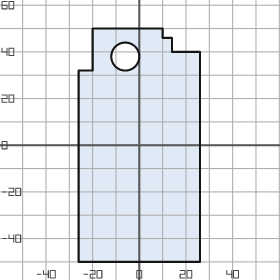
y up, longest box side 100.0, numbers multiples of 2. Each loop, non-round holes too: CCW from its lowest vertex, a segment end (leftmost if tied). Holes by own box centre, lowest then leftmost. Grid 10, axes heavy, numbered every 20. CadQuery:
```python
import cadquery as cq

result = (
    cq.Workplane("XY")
    .moveTo(-26.0, -50.0)
    .lineTo(26.0, -50.0)
    .lineTo(26.0, 40.0)
    .lineTo(14.0, 40.0)
    .lineTo(14.0, 46.0)
    .lineTo(10.0, 46.0)
    .lineTo(10.0, 50.0)
    .lineTo(-20.0, 50.0)
    .lineTo(-20.0, 32.0)
    .lineTo(-26.0, 32.0)
    .close()
    .moveTo(-6.0, 38.0)
    .circle(6.0)
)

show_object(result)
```